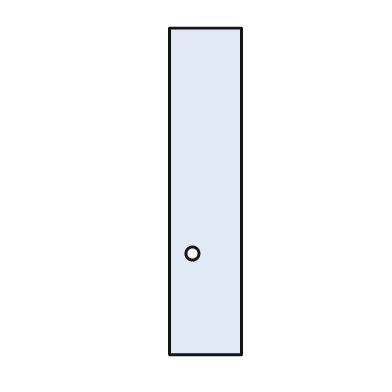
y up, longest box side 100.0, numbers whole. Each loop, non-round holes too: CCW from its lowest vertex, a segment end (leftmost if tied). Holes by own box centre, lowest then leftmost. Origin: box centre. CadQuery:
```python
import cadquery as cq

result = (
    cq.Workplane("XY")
    .moveTo(-11.0, -50.0)
    .lineTo(11.0, -50.0)
    .lineTo(11.0, 50.0)
    .lineTo(-11.0, 50.0)
    .close()
    .moveTo(-4.0, -19.0)
    .circle(2.0)
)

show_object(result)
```